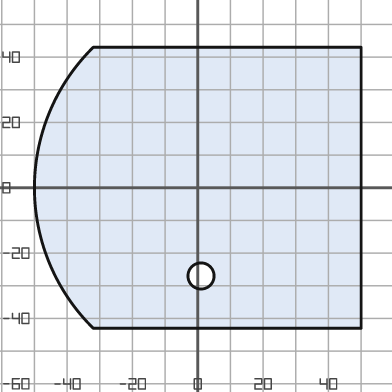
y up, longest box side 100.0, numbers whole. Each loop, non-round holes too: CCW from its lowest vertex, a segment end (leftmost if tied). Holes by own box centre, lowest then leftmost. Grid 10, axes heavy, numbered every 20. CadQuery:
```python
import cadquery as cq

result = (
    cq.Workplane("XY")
    .moveTo(-32.0, -43.0)
    .lineTo(50.0, -43.0)
    .lineTo(50.0, 43.0)
    .lineTo(-32.0, 43.0)
    .threePointArc((-50.0, 0.0), (-32.0, -43.0))
    .close()
    .moveTo(1.0, -27.0)
    .circle(4.0)
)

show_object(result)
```